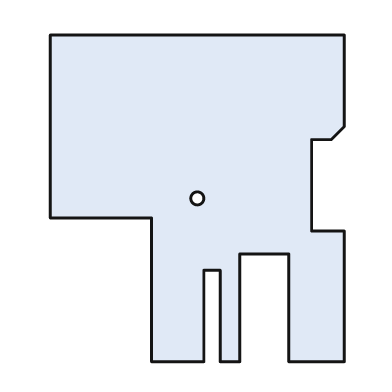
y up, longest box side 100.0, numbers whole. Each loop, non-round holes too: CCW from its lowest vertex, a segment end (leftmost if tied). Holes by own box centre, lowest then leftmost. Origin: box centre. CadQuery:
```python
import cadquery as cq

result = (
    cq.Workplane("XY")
    .moveTo(-14.0, -50.0)
    .lineTo(2.0, -50.0)
    .lineTo(2.0, -22.0)
    .lineTo(7.0, -22.0)
    .lineTo(7.0, -50.0)
    .lineTo(13.0, -50.0)
    .lineTo(13.0, -17.0)
    .lineTo(28.0, -17.0)
    .lineTo(28.0, -50.0)
    .lineTo(45.0, -50.0)
    .lineTo(45.0, -10.0)
    .lineTo(35.0, -10.0)
    .lineTo(35.0, 18.0)
    .lineTo(41.0, 18.0)
    .lineTo(45.0, 22.0)
    .lineTo(45.0, 50.0)
    .lineTo(-45.0, 50.0)
    .lineTo(-45.0, -6.0)
    .lineTo(-14.0, -6.0)
    .close()
    .moveTo(0.0, 0.0)
    .circle(2.0)
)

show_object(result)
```